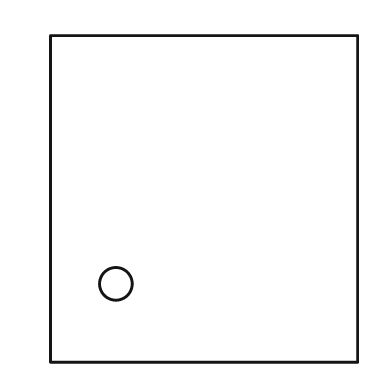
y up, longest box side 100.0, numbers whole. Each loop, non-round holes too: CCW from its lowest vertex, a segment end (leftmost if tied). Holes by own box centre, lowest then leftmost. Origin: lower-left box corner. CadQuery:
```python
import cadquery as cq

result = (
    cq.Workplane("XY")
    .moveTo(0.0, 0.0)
    .lineTo(94.0, 0.0)
    .lineTo(94.0, 100.0)
    .lineTo(0.0, 100.0)
    .close()
    .moveTo(20.0, 24.0)
    .circle(5.0)
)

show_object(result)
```